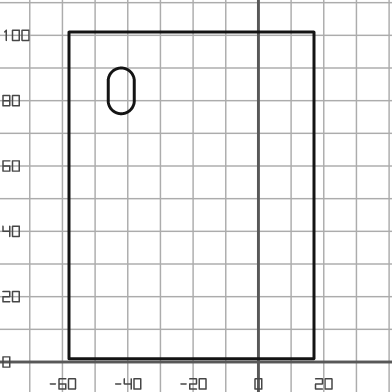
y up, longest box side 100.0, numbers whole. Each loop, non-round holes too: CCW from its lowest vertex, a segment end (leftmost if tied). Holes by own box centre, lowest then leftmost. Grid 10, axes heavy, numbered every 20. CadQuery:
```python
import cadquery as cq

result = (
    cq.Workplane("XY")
    .moveTo(-58.0, 1.0)
    .lineTo(17.0, 1.0)
    .lineTo(17.0, 101.0)
    .lineTo(-58.0, 101.0)
    .close()
    .moveTo(-46.0, 80.0)
    .threePointArc((-42.0, 76.0), (-38.0, 80.0))
    .lineTo(-38.0, 86.0)
    .threePointArc((-42.0, 90.0), (-46.0, 86.0))
    .close()
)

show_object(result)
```